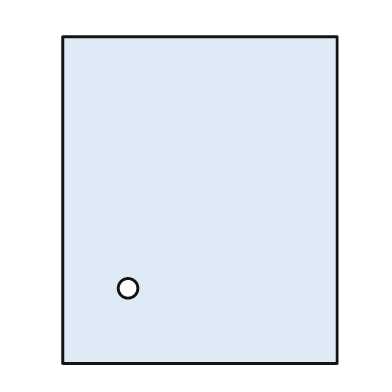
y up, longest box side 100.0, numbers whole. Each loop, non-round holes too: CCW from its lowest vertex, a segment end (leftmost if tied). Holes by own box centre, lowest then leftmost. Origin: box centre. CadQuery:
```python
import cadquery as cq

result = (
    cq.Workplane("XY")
    .moveTo(-42.0, -50.0)
    .lineTo(42.0, -50.0)
    .lineTo(42.0, 50.0)
    .lineTo(-42.0, 50.0)
    .close()
    .moveTo(-22.0, -27.0)
    .circle(3.0)
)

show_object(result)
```